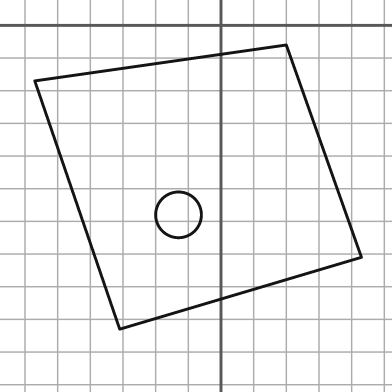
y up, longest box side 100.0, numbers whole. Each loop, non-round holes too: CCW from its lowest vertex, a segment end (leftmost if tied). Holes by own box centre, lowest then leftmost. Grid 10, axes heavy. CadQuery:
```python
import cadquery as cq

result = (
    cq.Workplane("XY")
    .moveTo(-31.0, -93.0)
    .lineTo(43.0, -71.0)
    .lineTo(20.0, -6.0)
    .lineTo(-57.0, -17.0)
    .close()
    .moveTo(-13.0, -58.0)
    .circle(7.0)
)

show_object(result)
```